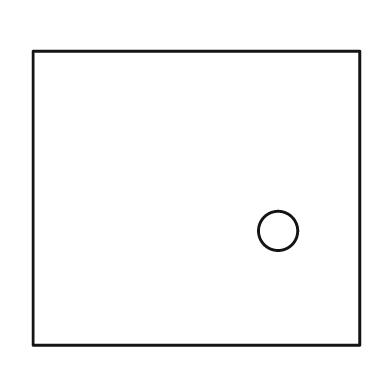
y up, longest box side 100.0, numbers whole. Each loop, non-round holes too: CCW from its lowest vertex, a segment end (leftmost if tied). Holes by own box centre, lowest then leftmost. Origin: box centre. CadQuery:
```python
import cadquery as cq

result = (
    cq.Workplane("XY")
    .moveTo(-50.0, -45.0)
    .lineTo(50.0, -45.0)
    .lineTo(50.0, 45.0)
    .lineTo(-50.0, 45.0)
    .close()
    .moveTo(25.0, -10.0)
    .circle(6.0)
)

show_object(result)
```